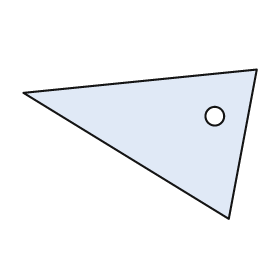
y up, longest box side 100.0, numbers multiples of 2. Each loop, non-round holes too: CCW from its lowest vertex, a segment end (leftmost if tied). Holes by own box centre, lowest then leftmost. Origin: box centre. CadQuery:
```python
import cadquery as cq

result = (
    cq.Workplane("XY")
    .moveTo(38.0, -32.0)
    .lineTo(50.0, 32.0)
    .lineTo(-50.0, 22.0)
    .close()
    .moveTo(32.0, 12.0)
    .circle(4.0)
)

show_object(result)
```